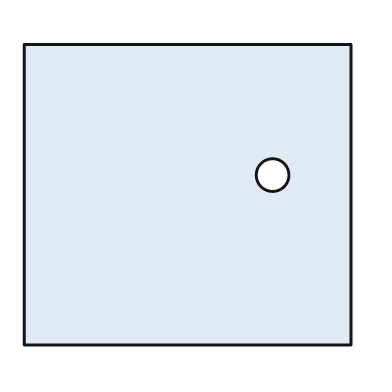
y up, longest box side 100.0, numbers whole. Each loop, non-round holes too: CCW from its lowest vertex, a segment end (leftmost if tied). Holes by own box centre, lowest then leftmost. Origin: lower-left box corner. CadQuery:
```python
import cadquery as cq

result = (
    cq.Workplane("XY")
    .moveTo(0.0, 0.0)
    .lineTo(100.0, 0.0)
    .lineTo(100.0, 92.0)
    .lineTo(0.0, 92.0)
    .close()
    .moveTo(76.0, 52.0)
    .circle(5.0)
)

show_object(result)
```